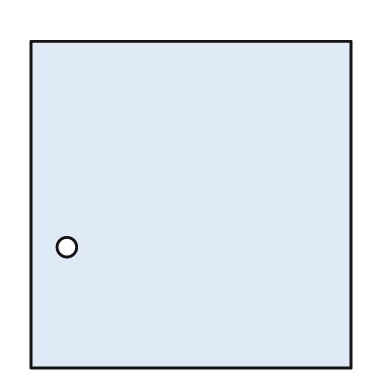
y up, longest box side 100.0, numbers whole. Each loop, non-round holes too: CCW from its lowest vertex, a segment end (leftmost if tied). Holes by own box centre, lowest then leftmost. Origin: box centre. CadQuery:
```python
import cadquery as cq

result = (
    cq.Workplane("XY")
    .moveTo(-49.0, -50.0)
    .lineTo(49.0, -50.0)
    .lineTo(49.0, 50.0)
    .lineTo(-49.0, 50.0)
    .close()
    .moveTo(-38.0, -13.0)
    .circle(3.0)
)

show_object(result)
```